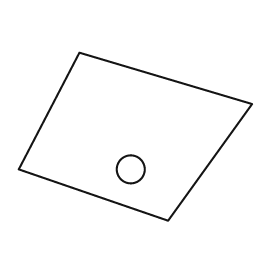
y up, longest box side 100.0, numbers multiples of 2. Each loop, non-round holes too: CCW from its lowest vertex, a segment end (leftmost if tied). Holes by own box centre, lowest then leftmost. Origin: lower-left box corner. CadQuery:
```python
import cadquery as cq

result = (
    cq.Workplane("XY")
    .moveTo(64.0, 0.0)
    .lineTo(100.0, 50.0)
    .lineTo(26.0, 72.0)
    .lineTo(0.0, 22.0)
    .close()
    .moveTo(48.0, 22.0)
    .circle(6.0)
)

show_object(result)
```